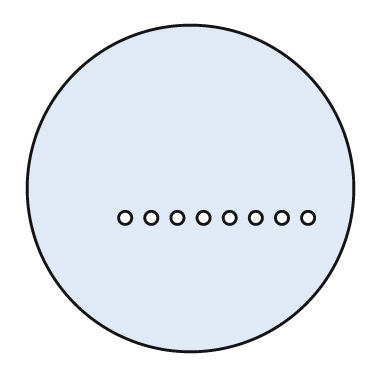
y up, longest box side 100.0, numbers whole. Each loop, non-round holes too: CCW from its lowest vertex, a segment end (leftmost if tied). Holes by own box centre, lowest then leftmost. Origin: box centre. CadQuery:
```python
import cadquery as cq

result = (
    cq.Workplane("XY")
    .moveTo(0.0, 0.0)
    .circle(50.0)
    .moveTo(-20.0, -9.0)
    .circle(2.0)
    .moveTo(-12.0, -9.0)
    .circle(2.0)
    .moveTo(-4.0, -9.0)
    .circle(2.0)
    .moveTo(4.0, -9.0)
    .circle(2.0)
    .moveTo(12.0, -9.0)
    .circle(2.0)
    .moveTo(20.0, -9.0)
    .circle(2.0)
    .moveTo(28.0, -9.0)
    .circle(2.0)
    .moveTo(36.0, -9.0)
    .circle(2.0)
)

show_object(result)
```